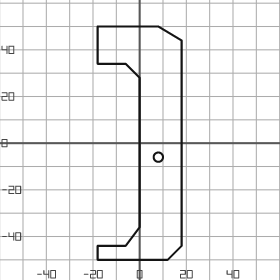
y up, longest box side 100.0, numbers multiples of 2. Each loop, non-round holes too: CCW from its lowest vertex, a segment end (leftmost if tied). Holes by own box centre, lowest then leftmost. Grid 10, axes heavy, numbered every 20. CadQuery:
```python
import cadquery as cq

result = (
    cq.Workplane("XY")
    .moveTo(-18.0, -50.0)
    .lineTo(12.0, -50.0)
    .lineTo(18.0, -44.0)
    .lineTo(18.0, 44.0)
    .lineTo(8.0, 50.0)
    .lineTo(-18.0, 50.0)
    .lineTo(-18.0, 34.0)
    .lineTo(-6.0, 34.0)
    .lineTo(0.0, 28.0)
    .lineTo(0.0, -36.0)
    .lineTo(-6.0, -44.0)
    .lineTo(-18.0, -44.0)
    .close()
    .moveTo(8.0, -6.0)
    .circle(2.0)
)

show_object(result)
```